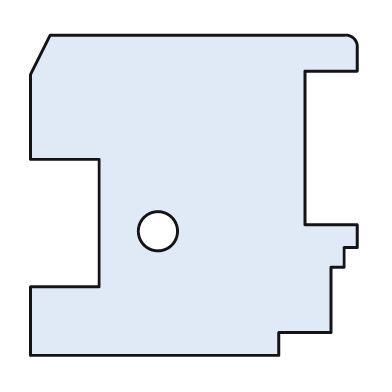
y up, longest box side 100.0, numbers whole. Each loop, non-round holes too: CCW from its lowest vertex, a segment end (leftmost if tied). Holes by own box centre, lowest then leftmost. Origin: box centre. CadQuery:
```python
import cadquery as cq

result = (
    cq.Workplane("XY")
    .moveTo(-50.0, -49.0)
    .lineTo(26.0, -49.0)
    .lineTo(26.0, -42.0)
    .lineTo(42.0, -42.0)
    .lineTo(42.0, -22.0)
    .lineTo(46.0, -22.0)
    .lineTo(46.0, -16.0)
    .lineTo(50.0, -16.0)
    .lineTo(50.0, -9.0)
    .lineTo(34.0, -9.0)
    .lineTo(34.0, 38.0)
    .lineTo(50.0, 38.0)
    .lineTo(50.0, 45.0)
    .threePointArc((49.0, 48.0), (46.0, 49.0))
    .lineTo(-44.0, 49.0)
    .lineTo(-50.0, 37.0)
    .lineTo(-50.0, 11.0)
    .lineTo(-29.0, 11.0)
    .lineTo(-29.0, -28.0)
    .lineTo(-50.0, -28.0)
    .close()
    .moveTo(-11.0, -11.0)
    .circle(6.0)
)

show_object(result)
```